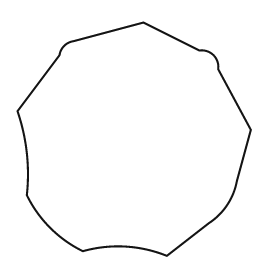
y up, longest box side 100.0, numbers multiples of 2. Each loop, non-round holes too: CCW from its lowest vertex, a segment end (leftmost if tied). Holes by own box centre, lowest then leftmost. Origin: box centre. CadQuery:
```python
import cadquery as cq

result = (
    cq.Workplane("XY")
    .moveTo(14.0, -50.0)
    .lineTo(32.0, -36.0)
    .threePointArc((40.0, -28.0), (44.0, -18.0))
    .lineTo(50.0, 4.0)
    .lineTo(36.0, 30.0)
    .threePointArc((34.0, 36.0), (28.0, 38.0))
    .lineTo(4.0, 50.0)
    .lineTo(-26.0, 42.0)
    .threePointArc((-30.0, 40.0), (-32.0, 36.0))
    .lineTo(-50.0, 12.0)
    .threePointArc((-46.0, -6.0), (-46.0, -24.0))
    .threePointArc((-36.0, -38.0), (-22.0, -48.0))
    .threePointArc((-4.0, -46.0), (14.0, -50.0))
    .close()
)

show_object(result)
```